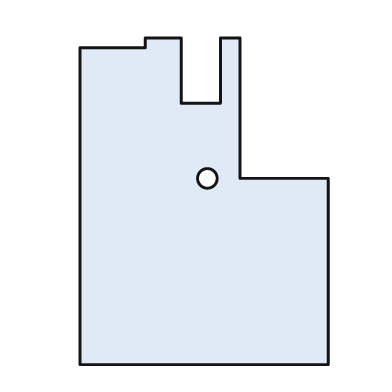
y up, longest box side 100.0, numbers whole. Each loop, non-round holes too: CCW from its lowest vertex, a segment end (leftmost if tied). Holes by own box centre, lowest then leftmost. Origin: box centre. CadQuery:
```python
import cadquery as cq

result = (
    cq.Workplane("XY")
    .moveTo(-38.0, -50.0)
    .lineTo(38.0, -50.0)
    .lineTo(38.0, 7.0)
    .lineTo(11.0, 7.0)
    .lineTo(11.0, 50.0)
    .lineTo(5.0, 50.0)
    .lineTo(5.0, 30.0)
    .lineTo(-7.0, 30.0)
    .lineTo(-7.0, 50.0)
    .lineTo(-18.0, 50.0)
    .lineTo(-18.0, 47.0)
    .lineTo(-38.0, 47.0)
    .close()
    .moveTo(1.0, 7.0)
    .circle(3.0)
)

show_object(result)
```